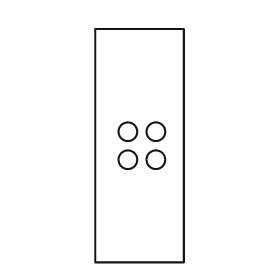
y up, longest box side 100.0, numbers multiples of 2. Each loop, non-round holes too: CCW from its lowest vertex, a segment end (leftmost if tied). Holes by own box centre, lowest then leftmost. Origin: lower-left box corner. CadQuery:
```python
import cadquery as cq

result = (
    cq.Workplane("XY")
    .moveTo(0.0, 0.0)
    .lineTo(38.0, 0.0)
    .lineTo(38.0, 100.0)
    .lineTo(0.0, 100.0)
    .close()
    .moveTo(14.0, 44.0)
    .circle(4.0)
    .moveTo(26.0, 44.0)
    .circle(4.0)
    .moveTo(14.0, 56.0)
    .circle(4.0)
    .moveTo(26.0, 56.0)
    .circle(4.0)
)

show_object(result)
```